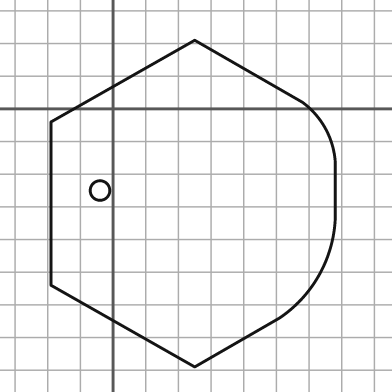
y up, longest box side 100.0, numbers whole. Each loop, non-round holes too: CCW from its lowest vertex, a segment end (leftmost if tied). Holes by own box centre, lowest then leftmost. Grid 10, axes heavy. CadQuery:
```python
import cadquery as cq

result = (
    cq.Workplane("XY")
    .moveTo(25.0, -79.0)
    .lineTo(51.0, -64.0)
    .threePointArc((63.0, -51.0), (68.0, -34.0))
    .lineTo(68.0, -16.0)
    .threePointArc((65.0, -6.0), (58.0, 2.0))
    .lineTo(25.0, 21.0)
    .lineTo(-19.0, -4.0)
    .lineTo(-19.0, -54.0)
    .close()
    .moveTo(-4.0, -25.0)
    .circle(3.0)
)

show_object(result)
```